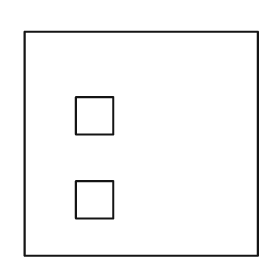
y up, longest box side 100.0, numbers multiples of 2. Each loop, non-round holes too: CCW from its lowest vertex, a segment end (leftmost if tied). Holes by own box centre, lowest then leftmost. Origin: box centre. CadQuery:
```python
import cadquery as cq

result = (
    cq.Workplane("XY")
    .moveTo(-50.0, -48.0)
    .lineTo(50.0, -48.0)
    .lineTo(50.0, 48.0)
    .lineTo(-50.0, 48.0)
    .close()
    .moveTo(-28.0, -32.0)
    .lineTo(-12.0, -32.0)
    .lineTo(-12.0, -16.0)
    .lineTo(-28.0, -16.0)
    .close()
    .moveTo(-28.0, 4.0)
    .lineTo(-12.0, 4.0)
    .lineTo(-12.0, 20.0)
    .lineTo(-28.0, 20.0)
    .close()
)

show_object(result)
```